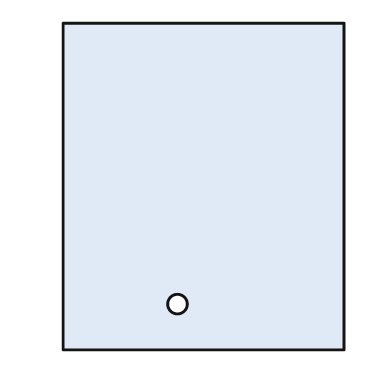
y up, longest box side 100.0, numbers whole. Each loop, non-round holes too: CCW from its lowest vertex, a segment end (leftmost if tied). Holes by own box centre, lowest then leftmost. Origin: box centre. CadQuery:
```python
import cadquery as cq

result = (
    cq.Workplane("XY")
    .moveTo(-43.0, -50.0)
    .lineTo(43.0, -50.0)
    .lineTo(43.0, 50.0)
    .lineTo(-43.0, 50.0)
    .close()
    .moveTo(-8.0, -36.0)
    .circle(3.0)
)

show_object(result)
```